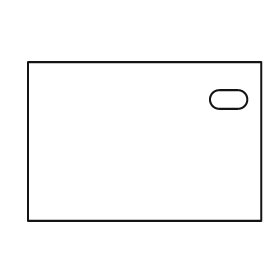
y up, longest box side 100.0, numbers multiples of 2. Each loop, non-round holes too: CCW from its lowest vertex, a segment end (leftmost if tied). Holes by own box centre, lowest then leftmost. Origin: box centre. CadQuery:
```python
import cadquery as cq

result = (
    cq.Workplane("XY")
    .moveTo(-50.0, -34.0)
    .lineTo(50.0, -34.0)
    .lineTo(50.0, 34.0)
    .lineTo(-50.0, 34.0)
    .close()
    .moveTo(32.0, 14.0)
    .lineTo(40.0, 14.0)
    .threePointArc((44.0, 18.0), (40.0, 22.0))
    .lineTo(32.0, 22.0)
    .threePointArc((28.0, 18.0), (32.0, 14.0))
    .close()
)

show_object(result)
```